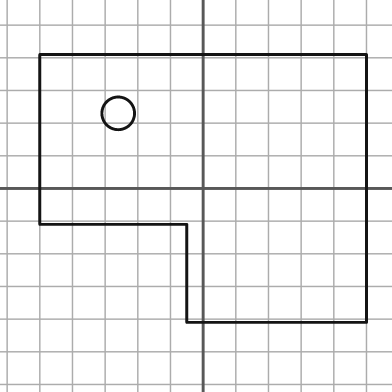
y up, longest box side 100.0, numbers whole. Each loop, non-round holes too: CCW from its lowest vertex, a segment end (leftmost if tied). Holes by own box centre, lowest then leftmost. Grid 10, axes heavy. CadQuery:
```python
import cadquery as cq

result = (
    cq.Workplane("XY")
    .moveTo(-5.0, -41.0)
    .lineTo(50.0, -41.0)
    .lineTo(50.0, 41.0)
    .lineTo(-50.0, 41.0)
    .lineTo(-50.0, -11.0)
    .lineTo(-5.0, -11.0)
    .close()
    .moveTo(-26.0, 23.0)
    .circle(5.0)
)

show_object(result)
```